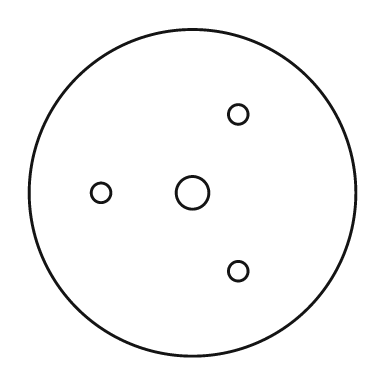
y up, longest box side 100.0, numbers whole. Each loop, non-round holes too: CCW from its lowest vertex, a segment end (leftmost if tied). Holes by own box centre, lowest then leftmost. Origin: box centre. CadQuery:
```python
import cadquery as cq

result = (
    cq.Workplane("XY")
    .moveTo(0.0, 0.0)
    .circle(50.0)
    .moveTo(14.0, -24.0)
    .circle(3.0)
    .moveTo(-28.0, 0.0)
    .circle(3.0)
    .moveTo(0.0, 0.0)
    .circle(5.0)
    .moveTo(14.0, 24.0)
    .circle(3.0)
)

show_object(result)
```